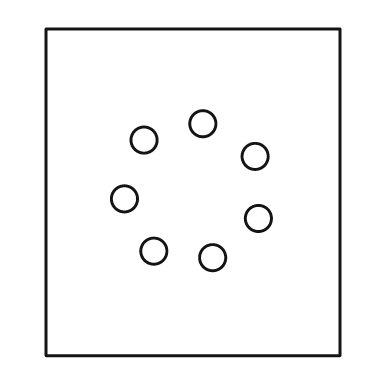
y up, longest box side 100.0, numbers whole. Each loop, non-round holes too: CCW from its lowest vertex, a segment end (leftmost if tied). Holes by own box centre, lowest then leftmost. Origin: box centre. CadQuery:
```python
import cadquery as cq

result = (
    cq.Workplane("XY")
    .moveTo(-45.0, -50.0)
    .lineTo(45.0, -50.0)
    .lineTo(45.0, 50.0)
    .lineTo(-45.0, 50.0)
    .close()
    .moveTo(6.0, -20.0)
    .circle(4.0)
    .moveTo(-12.0, -18.0)
    .circle(4.0)
    .moveTo(20.0, -8.0)
    .circle(4.0)
    .moveTo(-21.0, -2.0)
    .circle(4.0)
    .moveTo(19.0, 11.0)
    .circle(4.0)
    .moveTo(-15.0, 16.0)
    .circle(4.0)
    .moveTo(3.0, 21.0)
    .circle(4.0)
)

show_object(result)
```